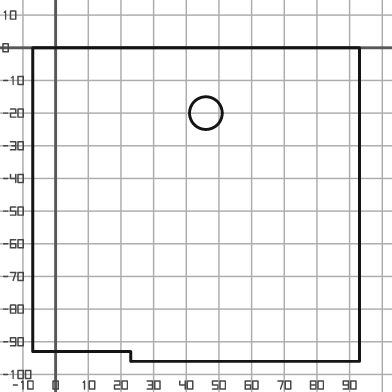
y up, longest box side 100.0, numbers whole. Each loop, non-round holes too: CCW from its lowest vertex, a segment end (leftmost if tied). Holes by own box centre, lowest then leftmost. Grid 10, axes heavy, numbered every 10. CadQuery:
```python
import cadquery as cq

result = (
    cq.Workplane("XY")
    .moveTo(23.0, -96.0)
    .lineTo(93.0, -96.0)
    .lineTo(93.0, 0.0)
    .lineTo(-7.0, 0.0)
    .lineTo(-7.0, -93.0)
    .lineTo(23.0, -93.0)
    .close()
    .moveTo(46.0, -20.0)
    .circle(5.0)
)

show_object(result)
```